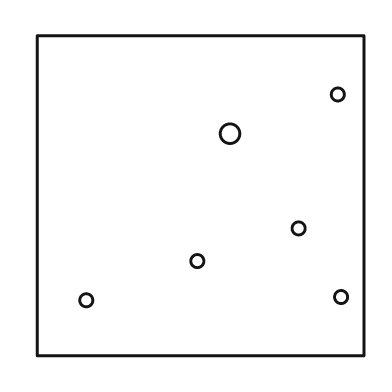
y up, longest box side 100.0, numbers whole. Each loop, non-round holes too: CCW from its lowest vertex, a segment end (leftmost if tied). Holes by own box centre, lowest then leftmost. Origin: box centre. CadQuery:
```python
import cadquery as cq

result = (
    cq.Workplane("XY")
    .moveTo(-50.0, -49.0)
    .lineTo(50.0, -49.0)
    .lineTo(50.0, 49.0)
    .lineTo(-50.0, 49.0)
    .close()
    .moveTo(-35.0, -32.0)
    .circle(2.0)
    .moveTo(43.0, -31.0)
    .circle(2.0)
    .moveTo(-1.0, -20.0)
    .circle(2.0)
    .moveTo(30.0, -10.0)
    .circle(2.0)
    .moveTo(9.0, 19.0)
    .circle(3.0)
    .moveTo(42.0, 31.0)
    .circle(2.0)
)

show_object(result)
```